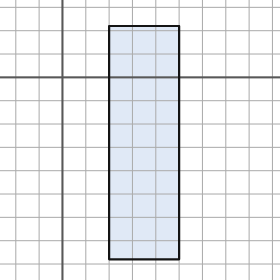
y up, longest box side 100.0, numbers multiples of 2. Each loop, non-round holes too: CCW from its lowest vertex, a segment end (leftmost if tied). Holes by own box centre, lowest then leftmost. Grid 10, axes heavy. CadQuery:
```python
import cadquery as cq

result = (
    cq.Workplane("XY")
    .moveTo(20.0, -78.0)
    .lineTo(50.0, -78.0)
    .lineTo(50.0, 22.0)
    .lineTo(20.0, 22.0)
    .close()
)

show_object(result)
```